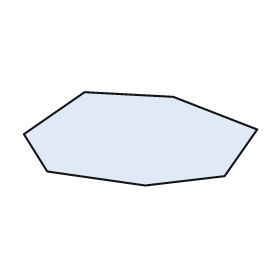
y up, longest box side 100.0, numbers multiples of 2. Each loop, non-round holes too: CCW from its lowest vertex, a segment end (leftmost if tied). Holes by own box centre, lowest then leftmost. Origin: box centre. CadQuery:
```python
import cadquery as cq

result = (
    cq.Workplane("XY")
    .moveTo(2.0, -20.0)
    .lineTo(36.0, -16.0)
    .lineTo(50.0, 4.0)
    .lineTo(14.0, 18.0)
    .lineTo(-24.0, 20.0)
    .lineTo(-50.0, 2.0)
    .lineTo(-40.0, -14.0)
    .close()
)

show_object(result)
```